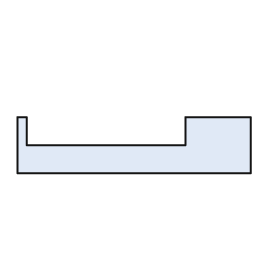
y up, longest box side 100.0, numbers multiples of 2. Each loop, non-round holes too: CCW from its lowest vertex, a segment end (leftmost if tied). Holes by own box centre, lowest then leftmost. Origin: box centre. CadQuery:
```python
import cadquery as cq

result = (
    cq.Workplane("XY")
    .moveTo(-50.0, -12.0)
    .lineTo(50.0, -12.0)
    .lineTo(50.0, 12.0)
    .lineTo(22.0, 12.0)
    .lineTo(22.0, 0.0)
    .lineTo(-46.0, 0.0)
    .lineTo(-46.0, 12.0)
    .lineTo(-50.0, 12.0)
    .close()
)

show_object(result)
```